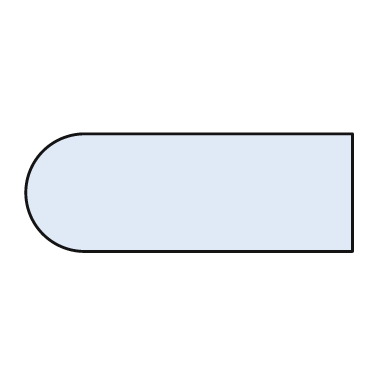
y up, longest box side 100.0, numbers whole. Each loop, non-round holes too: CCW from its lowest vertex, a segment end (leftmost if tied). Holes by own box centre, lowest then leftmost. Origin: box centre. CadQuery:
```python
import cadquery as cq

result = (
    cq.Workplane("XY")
    .moveTo(-32.0, -18.0)
    .lineTo(50.0, -18.0)
    .lineTo(50.0, 18.0)
    .lineTo(-32.0, 18.0)
    .threePointArc((-50.0, 0.0), (-32.0, -18.0))
    .close()
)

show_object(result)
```